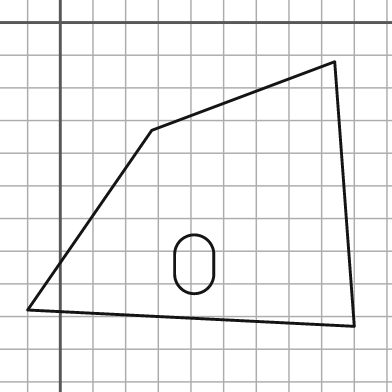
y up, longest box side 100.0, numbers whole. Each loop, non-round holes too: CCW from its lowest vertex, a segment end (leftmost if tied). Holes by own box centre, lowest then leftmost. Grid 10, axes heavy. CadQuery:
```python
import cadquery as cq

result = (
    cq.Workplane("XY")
    .moveTo(90.0, -93.0)
    .lineTo(84.0, -12.0)
    .lineTo(28.0, -33.0)
    .lineTo(-10.0, -88.0)
    .close()
    .moveTo(35.0, -77.0)
    .threePointArc((41.0, -83.0), (47.0, -77.0))
    .lineTo(47.0, -71.0)
    .threePointArc((41.0, -65.0), (35.0, -71.0))
    .close()
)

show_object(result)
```